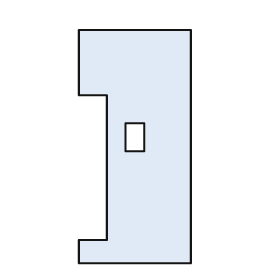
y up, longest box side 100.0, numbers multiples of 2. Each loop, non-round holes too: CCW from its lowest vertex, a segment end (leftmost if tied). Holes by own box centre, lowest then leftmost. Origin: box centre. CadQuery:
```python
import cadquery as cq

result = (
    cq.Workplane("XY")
    .moveTo(-24.0, -50.0)
    .lineTo(24.0, -50.0)
    .lineTo(24.0, 50.0)
    .lineTo(-24.0, 50.0)
    .lineTo(-24.0, 22.0)
    .lineTo(-12.0, 22.0)
    .lineTo(-12.0, -40.0)
    .lineTo(-24.0, -40.0)
    .close()
    .moveTo(-4.0, -2.0)
    .lineTo(4.0, -2.0)
    .lineTo(4.0, 10.0)
    .lineTo(-4.0, 10.0)
    .close()
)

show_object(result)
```